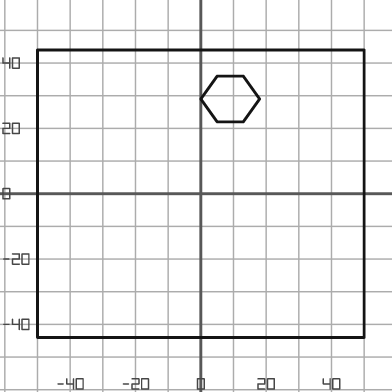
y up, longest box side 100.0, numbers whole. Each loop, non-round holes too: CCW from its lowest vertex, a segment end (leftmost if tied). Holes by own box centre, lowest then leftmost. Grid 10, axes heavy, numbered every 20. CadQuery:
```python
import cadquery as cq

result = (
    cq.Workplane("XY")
    .moveTo(-50.0, -44.0)
    .lineTo(50.0, -44.0)
    .lineTo(50.0, 44.0)
    .lineTo(-50.0, 44.0)
    .close()
    .moveTo(5.0, 22.0)
    .lineTo(13.0, 22.0)
    .lineTo(18.0, 29.0)
    .lineTo(13.0, 36.0)
    .lineTo(5.0, 36.0)
    .lineTo(0.0, 29.0)
    .close()
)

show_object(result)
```